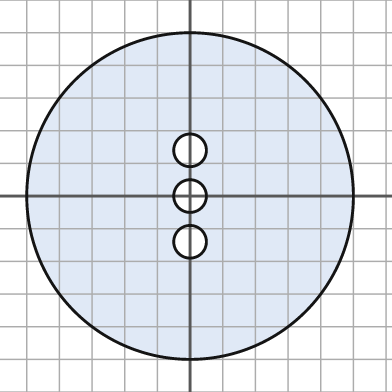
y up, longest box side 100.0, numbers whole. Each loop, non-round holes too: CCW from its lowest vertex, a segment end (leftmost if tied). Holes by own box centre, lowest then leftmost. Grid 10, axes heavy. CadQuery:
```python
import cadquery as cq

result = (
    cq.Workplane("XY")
    .moveTo(0.0, 0.0)
    .circle(50.0)
    .moveTo(0.0, -14.0)
    .circle(5.0)
    .moveTo(0.0, 0.0)
    .circle(5.0)
    .moveTo(0.0, 14.0)
    .circle(5.0)
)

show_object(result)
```